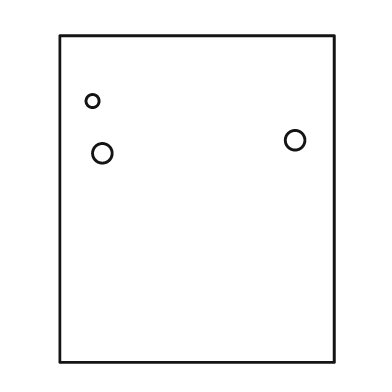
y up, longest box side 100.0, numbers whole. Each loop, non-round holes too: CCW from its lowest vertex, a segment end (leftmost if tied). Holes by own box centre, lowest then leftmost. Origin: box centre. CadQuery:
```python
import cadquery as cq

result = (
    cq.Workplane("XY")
    .moveTo(-42.0, -50.0)
    .lineTo(42.0, -50.0)
    .lineTo(42.0, 50.0)
    .lineTo(-42.0, 50.0)
    .close()
    .moveTo(-29.0, 14.0)
    .circle(3.0)
    .moveTo(30.0, 18.0)
    .circle(3.0)
    .moveTo(-32.0, 30.0)
    .circle(2.0)
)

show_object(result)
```